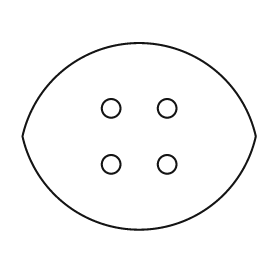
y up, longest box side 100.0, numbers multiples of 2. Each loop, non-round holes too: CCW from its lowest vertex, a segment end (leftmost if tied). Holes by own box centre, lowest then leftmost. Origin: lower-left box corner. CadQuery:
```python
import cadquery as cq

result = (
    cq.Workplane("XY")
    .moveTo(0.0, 40.0)
    .threePointArc((50.0, 0.0), (100.0, 40.0))
    .threePointArc((50.0, 80.0), (0.0, 40.0))
    .close()
    .moveTo(38.0, 28.0)
    .circle(4.0)
    .moveTo(62.0, 28.0)
    .circle(4.0)
    .moveTo(38.0, 52.0)
    .circle(4.0)
    .moveTo(62.0, 52.0)
    .circle(4.0)
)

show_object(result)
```